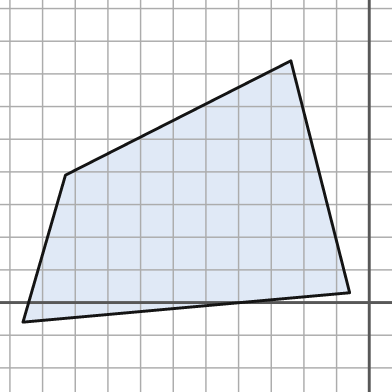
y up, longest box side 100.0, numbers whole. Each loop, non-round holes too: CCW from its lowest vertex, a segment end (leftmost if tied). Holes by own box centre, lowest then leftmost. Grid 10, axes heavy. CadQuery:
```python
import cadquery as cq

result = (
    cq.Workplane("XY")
    .moveTo(-106.0, -6.0)
    .lineTo(-6.0, 3.0)
    .lineTo(-24.0, 74.0)
    .lineTo(-93.0, 39.0)
    .close()
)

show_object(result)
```